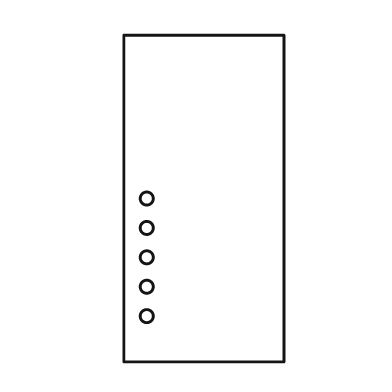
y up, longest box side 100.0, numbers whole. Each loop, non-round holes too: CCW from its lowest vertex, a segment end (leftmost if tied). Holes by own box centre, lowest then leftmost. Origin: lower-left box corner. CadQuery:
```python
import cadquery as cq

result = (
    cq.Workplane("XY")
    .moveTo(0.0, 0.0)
    .lineTo(49.0, 0.0)
    .lineTo(49.0, 100.0)
    .lineTo(0.0, 100.0)
    .close()
    .moveTo(7.0, 14.0)
    .circle(2.0)
    .moveTo(7.0, 23.0)
    .circle(2.0)
    .moveTo(7.0, 32.0)
    .circle(2.0)
    .moveTo(7.0, 41.0)
    .circle(2.0)
    .moveTo(7.0, 50.0)
    .circle(2.0)
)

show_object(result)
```